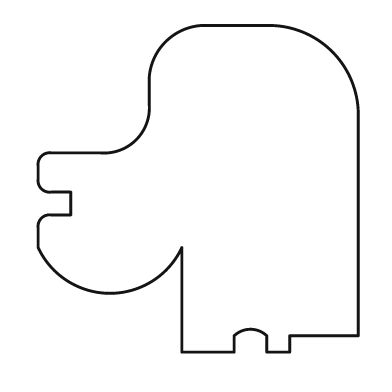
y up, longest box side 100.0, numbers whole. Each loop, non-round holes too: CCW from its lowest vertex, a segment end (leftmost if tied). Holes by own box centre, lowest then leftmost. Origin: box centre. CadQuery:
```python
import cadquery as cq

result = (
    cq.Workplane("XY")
    .moveTo(-5.0, -50.0)
    .lineTo(11.0, -50.0)
    .lineTo(11.0, -45.0)
    .threePointArc((16.0, -43.0), (21.0, -45.0))
    .lineTo(21.0, -50.0)
    .lineTo(28.0, -50.0)
    .lineTo(28.0, -45.0)
    .lineTo(49.0, -45.0)
    .lineTo(49.0, 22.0)
    .threePointArc((41.0, 42.0), (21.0, 50.0))
    .lineTo(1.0, 50.0)
    .threePointArc((-10.0, 45.0), (-15.0, 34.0))
    .lineTo(-15.0, 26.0)
    .threePointArc((-19.0, 15.0), (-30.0, 11.0))
    .lineTo(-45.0, 11.0)
    .threePointArc((-48.0, 10.0), (-49.0, 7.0))
    .lineTo(-49.0, 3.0)
    .threePointArc((-48.0, 0.0), (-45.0, -1.0))
    .lineTo(-39.0, -1.0)
    .lineTo(-39.0, -8.0)
    .lineTo(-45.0, -8.0)
    .threePointArc((-48.0, -9.0), (-49.0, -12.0))
    .lineTo(-49.0, -18.0)
    .threePointArc((-27.0, -32.0), (-5.0, -18.0))
    .close()
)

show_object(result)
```